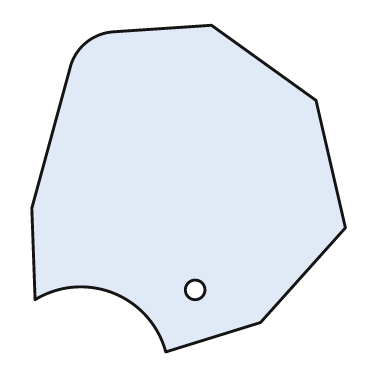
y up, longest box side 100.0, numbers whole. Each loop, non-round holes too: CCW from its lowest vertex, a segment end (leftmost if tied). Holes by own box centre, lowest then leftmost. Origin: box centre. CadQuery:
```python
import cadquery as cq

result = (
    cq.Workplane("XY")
    .moveTo(-7.0, -50.0)
    .lineTo(22.0, -41.0)
    .lineTo(48.0, -12.0)
    .lineTo(39.0, 27.0)
    .lineTo(7.0, 50.0)
    .lineTo(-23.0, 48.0)
    .threePointArc((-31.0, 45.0), (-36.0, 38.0))
    .lineTo(-48.0, -6.0)
    .lineTo(-47.0, -34.0)
    .threePointArc((-23.0, -32.0), (-7.0, -50.0))
    .close()
    .moveTo(2.0, -31.0)
    .circle(3.0)
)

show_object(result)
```